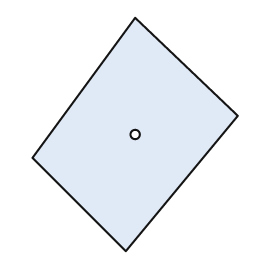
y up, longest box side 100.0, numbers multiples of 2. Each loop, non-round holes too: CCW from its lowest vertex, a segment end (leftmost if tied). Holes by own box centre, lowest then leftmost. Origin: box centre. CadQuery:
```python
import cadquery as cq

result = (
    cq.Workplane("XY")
    .moveTo(-4.0, -50.0)
    .lineTo(44.0, 8.0)
    .lineTo(0.0, 50.0)
    .lineTo(-44.0, -10.0)
    .close()
    .moveTo(0.0, 0.0)
    .circle(2.0)
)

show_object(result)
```